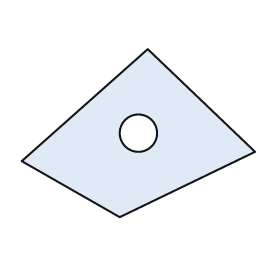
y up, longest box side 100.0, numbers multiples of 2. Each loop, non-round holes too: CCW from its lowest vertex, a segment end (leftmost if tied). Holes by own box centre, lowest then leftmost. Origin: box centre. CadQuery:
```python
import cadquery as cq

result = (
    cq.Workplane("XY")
    .moveTo(-8.0, -36.0)
    .lineTo(50.0, -8.0)
    .lineTo(4.0, 36.0)
    .lineTo(-50.0, -12.0)
    .close()
    .moveTo(0.0, 0.0)
    .circle(8.0)
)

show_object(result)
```